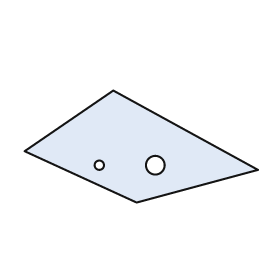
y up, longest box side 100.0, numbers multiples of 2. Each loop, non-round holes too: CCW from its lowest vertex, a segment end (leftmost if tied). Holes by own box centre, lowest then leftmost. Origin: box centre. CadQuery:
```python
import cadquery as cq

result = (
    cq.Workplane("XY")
    .moveTo(-2.0, -24.0)
    .lineTo(50.0, -10.0)
    .lineTo(-12.0, 24.0)
    .lineTo(-50.0, -2.0)
    .close()
    .moveTo(-18.0, -8.0)
    .circle(2.0)
    .moveTo(6.0, -8.0)
    .circle(4.0)
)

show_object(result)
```